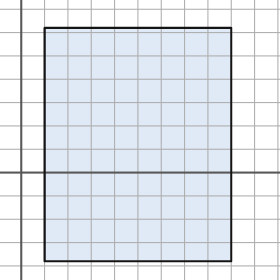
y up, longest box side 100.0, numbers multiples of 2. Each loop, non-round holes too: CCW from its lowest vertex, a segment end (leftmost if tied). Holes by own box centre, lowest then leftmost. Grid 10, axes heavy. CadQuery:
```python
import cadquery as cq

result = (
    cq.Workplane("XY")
    .moveTo(10.0, -38.0)
    .lineTo(90.0, -38.0)
    .lineTo(90.0, 62.0)
    .lineTo(10.0, 62.0)
    .close()
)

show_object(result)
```